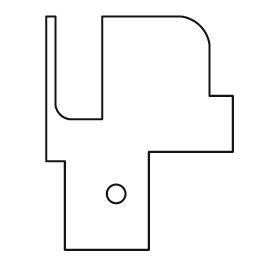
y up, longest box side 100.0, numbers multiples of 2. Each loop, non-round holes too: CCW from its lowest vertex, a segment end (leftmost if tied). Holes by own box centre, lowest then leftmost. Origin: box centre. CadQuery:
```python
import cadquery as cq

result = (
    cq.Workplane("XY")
    .moveTo(-32.0, -50.0)
    .lineTo(4.0, -50.0)
    .lineTo(4.0, -8.0)
    .lineTo(40.0, -8.0)
    .lineTo(40.0, 16.0)
    .lineTo(30.0, 16.0)
    .lineTo(30.0, 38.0)
    .threePointArc((26.0, 46.0), (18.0, 50.0))
    .lineTo(-16.0, 50.0)
    .lineTo(-16.0, 6.0)
    .lineTo(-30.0, 6.0)
    .threePointArc((-34.0, 8.0), (-36.0, 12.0))
    .lineTo(-36.0, 50.0)
    .lineTo(-40.0, 50.0)
    .lineTo(-40.0, -12.0)
    .lineTo(-32.0, -12.0)
    .close()
    .moveTo(-10.0, -26.0)
    .circle(4.0)
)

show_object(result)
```